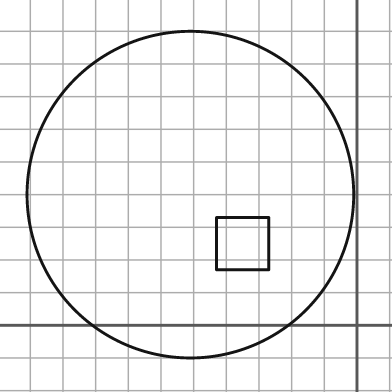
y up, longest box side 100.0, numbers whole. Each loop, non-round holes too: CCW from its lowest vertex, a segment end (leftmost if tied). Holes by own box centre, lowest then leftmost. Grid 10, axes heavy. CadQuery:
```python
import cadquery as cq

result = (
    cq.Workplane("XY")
    .moveTo(-51.0, 40.0)
    .circle(50.0)
    .moveTo(-43.0, 17.0)
    .lineTo(-27.0, 17.0)
    .lineTo(-27.0, 33.0)
    .lineTo(-43.0, 33.0)
    .close()
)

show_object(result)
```